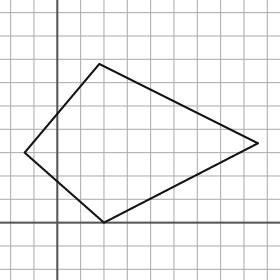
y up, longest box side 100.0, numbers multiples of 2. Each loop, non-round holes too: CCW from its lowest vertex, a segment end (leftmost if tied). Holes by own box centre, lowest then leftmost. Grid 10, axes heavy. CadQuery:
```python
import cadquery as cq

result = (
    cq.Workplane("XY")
    .moveTo(20.0, 0.0)
    .lineTo(86.0, 34.0)
    .lineTo(18.0, 68.0)
    .lineTo(-14.0, 30.0)
    .close()
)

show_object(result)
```